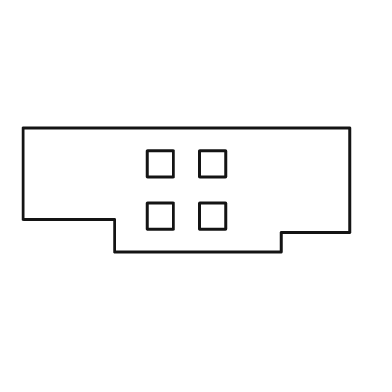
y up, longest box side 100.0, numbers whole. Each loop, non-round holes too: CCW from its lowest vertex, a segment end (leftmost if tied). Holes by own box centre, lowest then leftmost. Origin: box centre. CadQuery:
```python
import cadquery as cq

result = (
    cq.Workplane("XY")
    .moveTo(-22.0, -19.0)
    .lineTo(29.0, -19.0)
    .lineTo(29.0, -13.0)
    .lineTo(50.0, -13.0)
    .lineTo(50.0, 19.0)
    .lineTo(-50.0, 19.0)
    .lineTo(-50.0, -9.0)
    .lineTo(-22.0, -9.0)
    .close()
    .moveTo(-12.0, -12.0)
    .lineTo(-4.0, -12.0)
    .lineTo(-4.0, -4.0)
    .lineTo(-12.0, -4.0)
    .close()
    .moveTo(4.0, -12.0)
    .lineTo(12.0, -12.0)
    .lineTo(12.0, -4.0)
    .lineTo(4.0, -4.0)
    .close()
    .moveTo(-12.0, 4.0)
    .lineTo(-4.0, 4.0)
    .lineTo(-4.0, 12.0)
    .lineTo(-12.0, 12.0)
    .close()
    .moveTo(4.0, 4.0)
    .lineTo(12.0, 4.0)
    .lineTo(12.0, 12.0)
    .lineTo(4.0, 12.0)
    .close()
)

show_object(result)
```